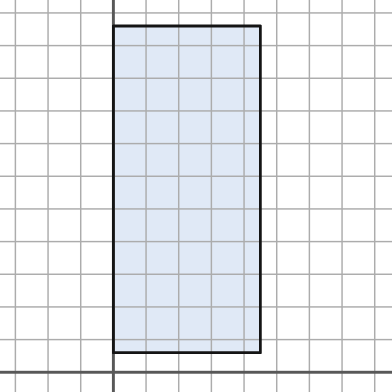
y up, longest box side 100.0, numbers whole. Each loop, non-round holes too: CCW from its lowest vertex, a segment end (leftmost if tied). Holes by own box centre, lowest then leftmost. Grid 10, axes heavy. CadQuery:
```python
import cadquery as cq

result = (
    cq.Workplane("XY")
    .moveTo(0.0, 6.0)
    .lineTo(45.0, 6.0)
    .lineTo(45.0, 106.0)
    .lineTo(0.0, 106.0)
    .close()
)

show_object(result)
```